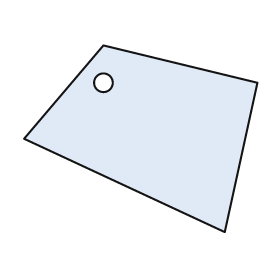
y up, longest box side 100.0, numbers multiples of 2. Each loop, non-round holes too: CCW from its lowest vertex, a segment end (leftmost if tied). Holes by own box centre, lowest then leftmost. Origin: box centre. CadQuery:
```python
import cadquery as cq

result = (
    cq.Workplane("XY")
    .moveTo(36.0, -40.0)
    .lineTo(50.0, 24.0)
    .lineTo(-16.0, 40.0)
    .lineTo(-50.0, 0.0)
    .close()
    .moveTo(-16.0, 24.0)
    .circle(4.0)
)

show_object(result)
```